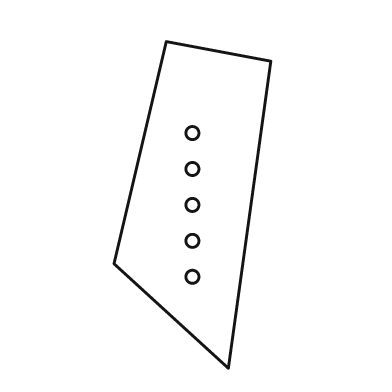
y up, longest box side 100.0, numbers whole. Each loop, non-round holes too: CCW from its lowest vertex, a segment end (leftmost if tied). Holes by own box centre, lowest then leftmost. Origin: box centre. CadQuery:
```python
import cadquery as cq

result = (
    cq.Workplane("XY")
    .moveTo(11.0, -50.0)
    .lineTo(24.0, 44.0)
    .lineTo(-8.0, 50.0)
    .lineTo(-24.0, -18.0)
    .close()
    .moveTo(0.0, -22.0)
    .circle(2.0)
    .moveTo(0.0, -11.0)
    .circle(2.0)
    .moveTo(0.0, 0.0)
    .circle(2.0)
    .moveTo(0.0, 11.0)
    .circle(2.0)
    .moveTo(0.0, 22.0)
    .circle(2.0)
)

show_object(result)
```